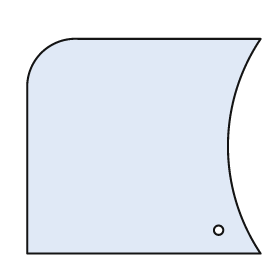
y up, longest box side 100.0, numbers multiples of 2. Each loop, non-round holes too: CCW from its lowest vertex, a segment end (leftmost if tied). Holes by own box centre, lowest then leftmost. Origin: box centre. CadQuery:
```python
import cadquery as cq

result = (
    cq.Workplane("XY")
    .moveTo(-50.0, -46.0)
    .lineTo(50.0, -46.0)
    .threePointArc((36.0, 0.0), (50.0, 46.0))
    .lineTo(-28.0, 46.0)
    .threePointArc((-44.0, 40.0), (-50.0, 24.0))
    .close()
    .moveTo(32.0, -36.0)
    .circle(2.0)
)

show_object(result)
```